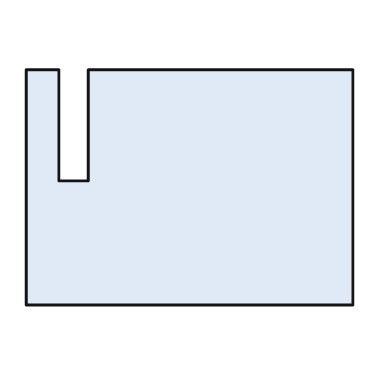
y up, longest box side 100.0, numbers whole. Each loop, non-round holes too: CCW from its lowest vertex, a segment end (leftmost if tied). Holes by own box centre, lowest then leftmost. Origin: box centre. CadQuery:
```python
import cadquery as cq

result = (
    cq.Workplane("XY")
    .moveTo(-50.0, -36.0)
    .lineTo(50.0, -36.0)
    .lineTo(50.0, 36.0)
    .lineTo(-31.0, 36.0)
    .lineTo(-31.0, 2.0)
    .lineTo(-40.0, 2.0)
    .lineTo(-40.0, 36.0)
    .lineTo(-50.0, 36.0)
    .close()
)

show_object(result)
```